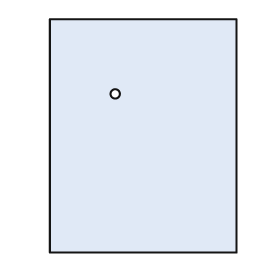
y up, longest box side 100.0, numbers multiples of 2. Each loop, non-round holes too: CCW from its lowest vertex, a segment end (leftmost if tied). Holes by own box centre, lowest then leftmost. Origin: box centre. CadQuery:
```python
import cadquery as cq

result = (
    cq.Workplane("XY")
    .moveTo(-40.0, -50.0)
    .lineTo(40.0, -50.0)
    .lineTo(40.0, 50.0)
    .lineTo(-40.0, 50.0)
    .close()
    .moveTo(-12.0, 18.0)
    .circle(2.0)
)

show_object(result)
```